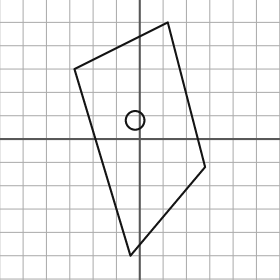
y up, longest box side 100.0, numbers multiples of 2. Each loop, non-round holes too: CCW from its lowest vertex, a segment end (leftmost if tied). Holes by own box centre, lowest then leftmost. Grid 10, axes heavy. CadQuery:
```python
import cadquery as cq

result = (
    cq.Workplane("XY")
    .moveTo(-4.0, -50.0)
    .lineTo(28.0, -12.0)
    .lineTo(12.0, 50.0)
    .lineTo(-28.0, 30.0)
    .close()
    .moveTo(-2.0, 8.0)
    .circle(4.0)
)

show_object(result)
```